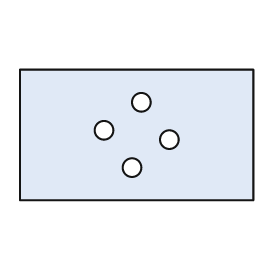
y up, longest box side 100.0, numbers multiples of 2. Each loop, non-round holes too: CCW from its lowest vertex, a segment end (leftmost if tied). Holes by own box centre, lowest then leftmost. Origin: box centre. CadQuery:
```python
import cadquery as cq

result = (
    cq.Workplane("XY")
    .moveTo(-50.0, -28.0)
    .lineTo(50.0, -28.0)
    .lineTo(50.0, 28.0)
    .lineTo(-50.0, 28.0)
    .close()
    .moveTo(-2.0, -14.0)
    .circle(4.0)
    .moveTo(14.0, -2.0)
    .circle(4.0)
    .moveTo(-14.0, 2.0)
    .circle(4.0)
    .moveTo(2.0, 14.0)
    .circle(4.0)
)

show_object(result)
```